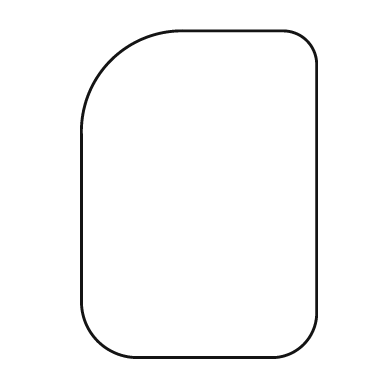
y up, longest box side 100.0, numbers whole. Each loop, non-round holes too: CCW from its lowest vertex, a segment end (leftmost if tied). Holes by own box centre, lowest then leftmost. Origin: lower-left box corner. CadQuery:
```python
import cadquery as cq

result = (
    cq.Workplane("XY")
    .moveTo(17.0, 0.0)
    .lineTo(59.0, 0.0)
    .threePointArc((68.0, 4.0), (72.0, 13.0))
    .lineTo(72.0, 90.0)
    .threePointArc((69.0, 97.0), (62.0, 100.0))
    .lineTo(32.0, 100.0)
    .threePointArc((9.0, 91.0), (0.0, 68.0))
    .lineTo(0.0, 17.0)
    .threePointArc((5.0, 5.0), (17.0, 0.0))
    .close()
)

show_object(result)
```